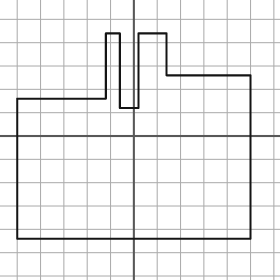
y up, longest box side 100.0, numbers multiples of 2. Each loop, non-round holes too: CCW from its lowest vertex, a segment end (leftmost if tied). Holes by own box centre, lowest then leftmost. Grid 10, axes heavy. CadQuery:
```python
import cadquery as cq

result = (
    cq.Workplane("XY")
    .moveTo(-50.0, -44.0)
    .lineTo(50.0, -44.0)
    .lineTo(50.0, 26.0)
    .lineTo(14.0, 26.0)
    .lineTo(14.0, 44.0)
    .lineTo(2.0, 44.0)
    .lineTo(2.0, 12.0)
    .lineTo(-6.0, 12.0)
    .lineTo(-6.0, 44.0)
    .lineTo(-12.0, 44.0)
    .lineTo(-12.0, 16.0)
    .lineTo(-50.0, 16.0)
    .close()
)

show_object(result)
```